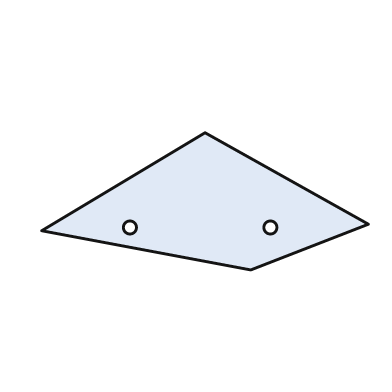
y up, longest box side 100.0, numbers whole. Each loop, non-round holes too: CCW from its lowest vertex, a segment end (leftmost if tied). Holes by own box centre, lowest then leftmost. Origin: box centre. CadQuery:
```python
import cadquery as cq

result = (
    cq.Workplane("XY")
    .moveTo(14.0, -21.0)
    .lineTo(50.0, -7.0)
    .lineTo(0.0, 21.0)
    .lineTo(-50.0, -9.0)
    .close()
    .moveTo(-23.0, -8.0)
    .circle(2.0)
    .moveTo(20.0, -8.0)
    .circle(2.0)
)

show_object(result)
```